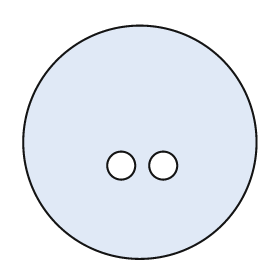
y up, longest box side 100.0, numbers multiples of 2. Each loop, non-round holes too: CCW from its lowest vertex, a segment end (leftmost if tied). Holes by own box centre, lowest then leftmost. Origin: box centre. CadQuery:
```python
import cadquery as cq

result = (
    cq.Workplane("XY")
    .moveTo(0.0, 0.0)
    .circle(50.0)
    .moveTo(-8.0, -10.0)
    .circle(6.0)
    .moveTo(10.0, -10.0)
    .circle(6.0)
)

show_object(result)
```